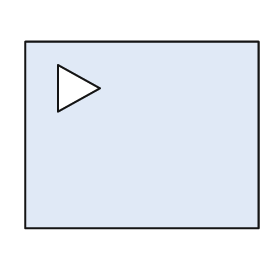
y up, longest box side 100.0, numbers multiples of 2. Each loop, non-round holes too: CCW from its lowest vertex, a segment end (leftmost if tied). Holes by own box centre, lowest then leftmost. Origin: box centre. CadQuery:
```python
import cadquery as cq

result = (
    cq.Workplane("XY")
    .moveTo(-50.0, -40.0)
    .lineTo(50.0, -40.0)
    .lineTo(50.0, 40.0)
    .lineTo(-50.0, 40.0)
    .close()
    .moveTo(-36.0, 10.0)
    .lineTo(-18.0, 20.0)
    .lineTo(-36.0, 30.0)
    .close()
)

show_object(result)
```